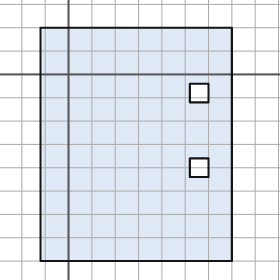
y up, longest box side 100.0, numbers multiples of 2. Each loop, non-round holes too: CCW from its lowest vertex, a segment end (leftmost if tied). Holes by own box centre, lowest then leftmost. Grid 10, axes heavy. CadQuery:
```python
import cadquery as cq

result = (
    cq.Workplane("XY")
    .moveTo(-12.0, -80.0)
    .lineTo(70.0, -80.0)
    .lineTo(70.0, 20.0)
    .lineTo(-12.0, 20.0)
    .close()
    .moveTo(52.0, -44.0)
    .lineTo(60.0, -44.0)
    .lineTo(60.0, -36.0)
    .lineTo(52.0, -36.0)
    .close()
    .moveTo(52.0, -12.0)
    .lineTo(60.0, -12.0)
    .lineTo(60.0, -4.0)
    .lineTo(52.0, -4.0)
    .close()
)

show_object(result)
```